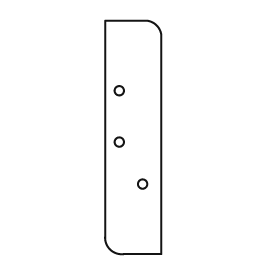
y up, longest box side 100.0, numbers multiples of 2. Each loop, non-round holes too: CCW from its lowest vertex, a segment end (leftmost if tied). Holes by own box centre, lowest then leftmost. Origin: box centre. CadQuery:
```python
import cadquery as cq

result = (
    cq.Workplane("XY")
    .moveTo(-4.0, -50.0)
    .lineTo(12.0, -50.0)
    .lineTo(12.0, 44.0)
    .threePointArc((10.0, 48.0), (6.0, 50.0))
    .lineTo(-12.0, 50.0)
    .lineTo(-12.0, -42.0)
    .threePointArc((-10.0, -48.0), (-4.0, -50.0))
    .close()
    .moveTo(4.0, -20.0)
    .circle(2.0)
    .moveTo(-6.0, -2.0)
    .circle(2.0)
    .moveTo(-6.0, 20.0)
    .circle(2.0)
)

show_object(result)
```